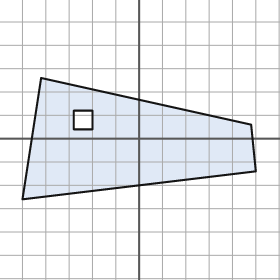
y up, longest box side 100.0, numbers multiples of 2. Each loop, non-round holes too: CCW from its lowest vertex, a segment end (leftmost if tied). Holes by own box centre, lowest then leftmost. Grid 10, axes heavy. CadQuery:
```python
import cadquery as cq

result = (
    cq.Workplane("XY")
    .moveTo(-50.0, -26.0)
    .lineTo(50.0, -14.0)
    .lineTo(48.0, 6.0)
    .lineTo(-42.0, 26.0)
    .close()
    .moveTo(-28.0, 4.0)
    .lineTo(-20.0, 4.0)
    .lineTo(-20.0, 12.0)
    .lineTo(-28.0, 12.0)
    .close()
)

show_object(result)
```